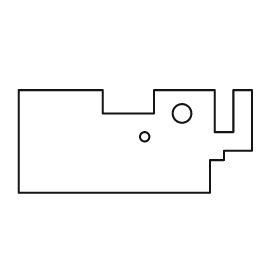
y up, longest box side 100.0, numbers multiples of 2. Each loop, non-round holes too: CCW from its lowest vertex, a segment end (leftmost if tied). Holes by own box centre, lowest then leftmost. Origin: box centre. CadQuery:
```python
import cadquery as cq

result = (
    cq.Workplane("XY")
    .moveTo(-50.0, -22.0)
    .lineTo(32.0, -22.0)
    .lineTo(32.0, -8.0)
    .lineTo(38.0, -8.0)
    .lineTo(38.0, -4.0)
    .lineTo(50.0, -4.0)
    .lineTo(50.0, 22.0)
    .lineTo(42.0, 22.0)
    .lineTo(42.0, 4.0)
    .lineTo(34.0, 4.0)
    .lineTo(34.0, 22.0)
    .lineTo(8.0, 22.0)
    .lineTo(8.0, 12.0)
    .lineTo(-14.0, 12.0)
    .lineTo(-14.0, 22.0)
    .lineTo(-50.0, 22.0)
    .close()
    .moveTo(4.0, 2.0)
    .circle(2.0)
    .moveTo(20.0, 12.0)
    .circle(4.0)
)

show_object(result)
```